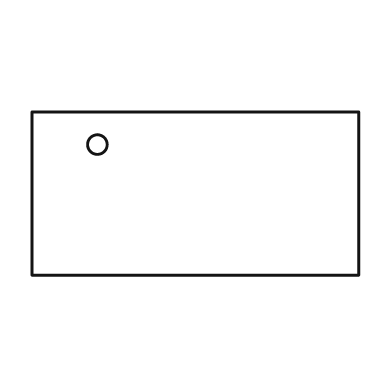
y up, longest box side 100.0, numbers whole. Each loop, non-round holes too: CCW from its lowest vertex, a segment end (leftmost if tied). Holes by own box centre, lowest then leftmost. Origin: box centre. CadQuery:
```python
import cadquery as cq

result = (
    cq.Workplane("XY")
    .moveTo(-50.0, -25.0)
    .lineTo(50.0, -25.0)
    .lineTo(50.0, 25.0)
    .lineTo(-50.0, 25.0)
    .close()
    .moveTo(-30.0, 15.0)
    .circle(3.0)
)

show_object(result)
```